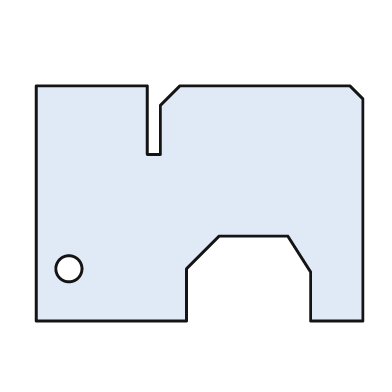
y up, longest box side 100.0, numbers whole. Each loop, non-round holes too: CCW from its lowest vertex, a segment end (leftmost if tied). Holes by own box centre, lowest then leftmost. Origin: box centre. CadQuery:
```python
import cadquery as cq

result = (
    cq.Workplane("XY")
    .moveTo(-50.0, -36.0)
    .lineTo(-4.0, -36.0)
    .lineTo(-4.0, -20.0)
    .lineTo(6.0, -10.0)
    .lineTo(27.0, -10.0)
    .lineTo(34.0, -21.0)
    .lineTo(34.0, -36.0)
    .lineTo(50.0, -36.0)
    .lineTo(50.0, 32.0)
    .lineTo(46.0, 36.0)
    .lineTo(-6.0, 36.0)
    .lineTo(-12.0, 30.0)
    .lineTo(-12.0, 15.0)
    .lineTo(-16.0, 15.0)
    .lineTo(-16.0, 36.0)
    .lineTo(-50.0, 36.0)
    .close()
    .moveTo(-40.0, -20.0)
    .circle(4.0)
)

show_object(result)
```